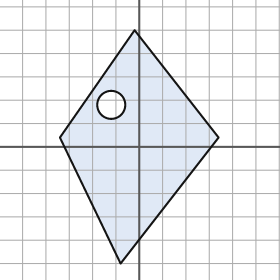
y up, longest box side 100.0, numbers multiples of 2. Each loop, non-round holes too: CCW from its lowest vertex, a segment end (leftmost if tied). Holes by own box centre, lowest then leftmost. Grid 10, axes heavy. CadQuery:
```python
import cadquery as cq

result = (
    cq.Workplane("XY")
    .moveTo(-8.0, -50.0)
    .lineTo(34.0, 4.0)
    .lineTo(-2.0, 50.0)
    .lineTo(-34.0, 4.0)
    .close()
    .moveTo(-12.0, 18.0)
    .circle(6.0)
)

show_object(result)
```